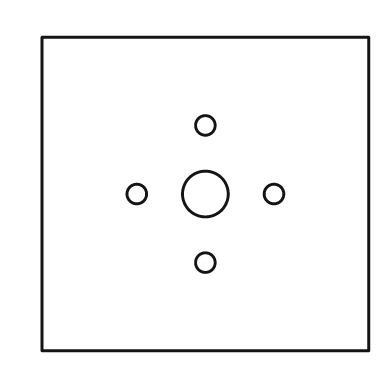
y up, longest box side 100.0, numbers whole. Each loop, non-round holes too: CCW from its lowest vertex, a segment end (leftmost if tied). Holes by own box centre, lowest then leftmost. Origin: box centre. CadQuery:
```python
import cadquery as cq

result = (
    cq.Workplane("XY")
    .moveTo(-50.0, -48.0)
    .lineTo(50.0, -48.0)
    .lineTo(50.0, 48.0)
    .lineTo(-50.0, 48.0)
    .close()
    .moveTo(0.0, -21.0)
    .circle(3.0)
    .moveTo(-21.0, 0.0)
    .circle(3.0)
    .moveTo(0.0, 0.0)
    .circle(7.0)
    .moveTo(21.0, 0.0)
    .circle(3.0)
    .moveTo(0.0, 21.0)
    .circle(3.0)
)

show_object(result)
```